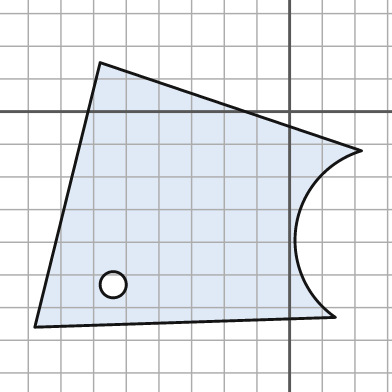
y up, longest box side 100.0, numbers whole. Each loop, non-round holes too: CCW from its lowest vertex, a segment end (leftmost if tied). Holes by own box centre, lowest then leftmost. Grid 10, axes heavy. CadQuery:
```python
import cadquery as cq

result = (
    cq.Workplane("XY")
    .moveTo(-78.0, -66.0)
    .lineTo(14.0, -63.0)
    .threePointArc((2.0, -35.0), (22.0, -12.0))
    .lineTo(-58.0, 15.0)
    .close()
    .moveTo(-54.0, -53.0)
    .circle(4.0)
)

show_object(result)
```